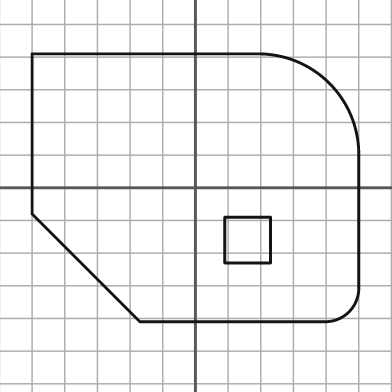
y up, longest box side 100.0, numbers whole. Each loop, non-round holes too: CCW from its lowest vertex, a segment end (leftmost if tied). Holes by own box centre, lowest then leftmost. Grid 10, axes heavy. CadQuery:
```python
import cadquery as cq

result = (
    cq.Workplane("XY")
    .moveTo(-17.0, -41.0)
    .lineTo(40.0, -41.0)
    .threePointArc((47.0, -38.0), (50.0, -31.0))
    .lineTo(50.0, 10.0)
    .threePointArc((41.0, 32.0), (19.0, 41.0))
    .lineTo(-50.0, 41.0)
    .lineTo(-50.0, -8.0)
    .close()
    .moveTo(9.0, -23.0)
    .lineTo(23.0, -23.0)
    .lineTo(23.0, -9.0)
    .lineTo(9.0, -9.0)
    .close()
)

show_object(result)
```